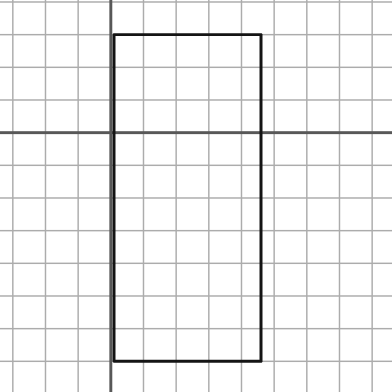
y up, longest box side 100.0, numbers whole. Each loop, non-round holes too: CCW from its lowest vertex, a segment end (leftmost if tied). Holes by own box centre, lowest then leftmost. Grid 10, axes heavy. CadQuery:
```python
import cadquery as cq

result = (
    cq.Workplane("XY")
    .moveTo(1.0, -70.0)
    .lineTo(46.0, -70.0)
    .lineTo(46.0, 30.0)
    .lineTo(1.0, 30.0)
    .close()
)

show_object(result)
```